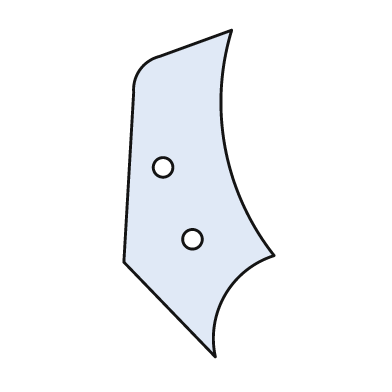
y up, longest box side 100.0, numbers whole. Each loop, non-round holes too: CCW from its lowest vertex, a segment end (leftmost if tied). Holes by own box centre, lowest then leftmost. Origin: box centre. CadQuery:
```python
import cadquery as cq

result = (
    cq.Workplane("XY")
    .moveTo(5.0, -50.0)
    .threePointArc((8.0, -31.0), (23.0, -19.0))
    .threePointArc((8.0, 14.0), (10.0, 50.0))
    .lineTo(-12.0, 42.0)
    .threePointArc((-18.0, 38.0), (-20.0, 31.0))
    .lineTo(-23.0, -21.0)
    .close()
    .moveTo(-2.0, -14.0)
    .circle(3.0)
    .moveTo(-11.0, 8.0)
    .circle(3.0)
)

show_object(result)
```